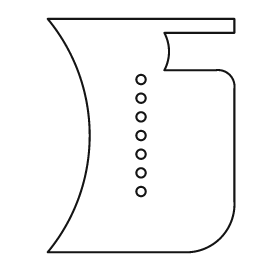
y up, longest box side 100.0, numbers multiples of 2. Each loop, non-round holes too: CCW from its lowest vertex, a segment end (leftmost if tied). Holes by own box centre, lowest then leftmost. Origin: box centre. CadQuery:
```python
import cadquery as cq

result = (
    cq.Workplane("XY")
    .moveTo(-40.0, -50.0)
    .lineTo(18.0, -50.0)
    .threePointArc((34.0, -44.0), (40.0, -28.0))
    .lineTo(40.0, 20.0)
    .threePointArc((38.0, 26.0), (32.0, 28.0))
    .lineTo(10.0, 28.0)
    .threePointArc((12.0, 36.0), (10.0, 44.0))
    .lineTo(40.0, 44.0)
    .lineTo(40.0, 50.0)
    .lineTo(-40.0, 50.0)
    .threePointArc((-22.0, 0.0), (-40.0, -50.0))
    .close()
    .moveTo(0.0, -24.0)
    .circle(2.0)
    .moveTo(0.0, -16.0)
    .circle(2.0)
    .moveTo(0.0, -8.0)
    .circle(2.0)
    .moveTo(0.0, 0.0)
    .circle(2.0)
    .moveTo(0.0, 8.0)
    .circle(2.0)
    .moveTo(0.0, 16.0)
    .circle(2.0)
    .moveTo(0.0, 24.0)
    .circle(2.0)
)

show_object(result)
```